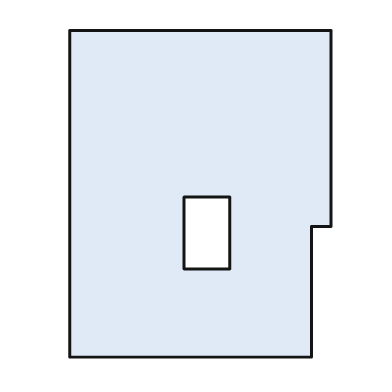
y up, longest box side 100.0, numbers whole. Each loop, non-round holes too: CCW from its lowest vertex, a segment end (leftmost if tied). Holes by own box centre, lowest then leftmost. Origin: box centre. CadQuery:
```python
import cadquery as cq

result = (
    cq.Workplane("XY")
    .moveTo(-40.0, -50.0)
    .lineTo(34.0, -50.0)
    .lineTo(34.0, -10.0)
    .lineTo(40.0, -10.0)
    .lineTo(40.0, 50.0)
    .lineTo(-40.0, 50.0)
    .close()
    .moveTo(-5.0, -23.0)
    .lineTo(9.0, -23.0)
    .lineTo(9.0, -1.0)
    .lineTo(-5.0, -1.0)
    .close()
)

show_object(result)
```